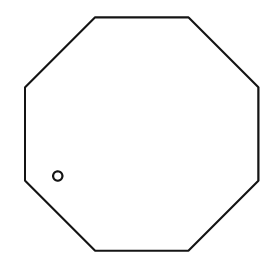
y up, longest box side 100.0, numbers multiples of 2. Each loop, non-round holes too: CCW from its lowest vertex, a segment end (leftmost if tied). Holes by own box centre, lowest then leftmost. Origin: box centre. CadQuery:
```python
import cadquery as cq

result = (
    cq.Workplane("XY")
    .moveTo(-20.0, -50.0)
    .lineTo(20.0, -50.0)
    .lineTo(50.0, -20.0)
    .lineTo(50.0, 20.0)
    .lineTo(20.0, 50.0)
    .lineTo(-20.0, 50.0)
    .lineTo(-50.0, 20.0)
    .lineTo(-50.0, -20.0)
    .close()
    .moveTo(-36.0, -18.0)
    .circle(2.0)
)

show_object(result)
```